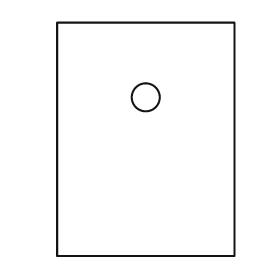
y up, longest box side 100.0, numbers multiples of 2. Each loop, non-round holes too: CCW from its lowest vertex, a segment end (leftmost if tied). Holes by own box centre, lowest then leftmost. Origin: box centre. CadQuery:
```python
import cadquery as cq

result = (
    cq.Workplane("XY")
    .moveTo(-38.0, -50.0)
    .lineTo(38.0, -50.0)
    .lineTo(38.0, 50.0)
    .lineTo(-38.0, 50.0)
    .close()
    .moveTo(0.0, 18.0)
    .circle(6.0)
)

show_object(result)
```